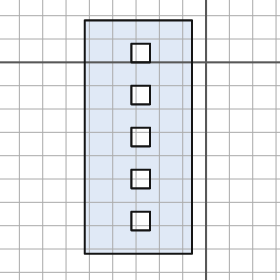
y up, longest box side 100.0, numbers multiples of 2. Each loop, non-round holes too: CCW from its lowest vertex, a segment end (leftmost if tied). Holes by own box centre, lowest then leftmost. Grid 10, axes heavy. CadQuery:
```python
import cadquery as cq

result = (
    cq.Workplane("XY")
    .moveTo(-52.0, -82.0)
    .lineTo(-6.0, -82.0)
    .lineTo(-6.0, 18.0)
    .lineTo(-52.0, 18.0)
    .close()
    .moveTo(-32.0, -72.0)
    .lineTo(-24.0, -72.0)
    .lineTo(-24.0, -64.0)
    .lineTo(-32.0, -64.0)
    .close()
    .moveTo(-32.0, -54.0)
    .lineTo(-24.0, -54.0)
    .lineTo(-24.0, -46.0)
    .lineTo(-32.0, -46.0)
    .close()
    .moveTo(-32.0, -36.0)
    .lineTo(-24.0, -36.0)
    .lineTo(-24.0, -28.0)
    .lineTo(-32.0, -28.0)
    .close()
    .moveTo(-32.0, -18.0)
    .lineTo(-24.0, -18.0)
    .lineTo(-24.0, -10.0)
    .lineTo(-32.0, -10.0)
    .close()
    .moveTo(-32.0, 0.0)
    .lineTo(-24.0, 0.0)
    .lineTo(-24.0, 8.0)
    .lineTo(-32.0, 8.0)
    .close()
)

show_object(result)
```